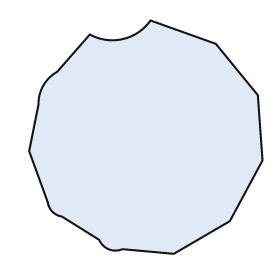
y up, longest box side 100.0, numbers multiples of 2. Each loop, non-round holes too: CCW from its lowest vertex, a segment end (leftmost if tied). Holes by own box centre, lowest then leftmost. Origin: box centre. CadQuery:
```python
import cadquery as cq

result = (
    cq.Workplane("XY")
    .moveTo(12.0, -50.0)
    .lineTo(36.0, -36.0)
    .lineTo(50.0, -10.0)
    .lineTo(48.0, 18.0)
    .lineTo(30.0, 40.0)
    .lineTo(2.0, 50.0)
    .threePointArc((-10.0, 42.0), (-24.0, 44.0))
    .lineTo(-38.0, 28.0)
    .threePointArc((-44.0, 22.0), (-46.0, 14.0))
    .lineTo(-50.0, -6.0)
    .lineTo(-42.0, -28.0)
    .threePointArc((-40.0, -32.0), (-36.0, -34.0))
    .lineTo(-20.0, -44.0)
    .threePointArc((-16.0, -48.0), (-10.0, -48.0))
    .close()
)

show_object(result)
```